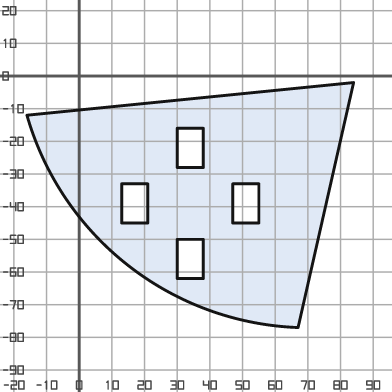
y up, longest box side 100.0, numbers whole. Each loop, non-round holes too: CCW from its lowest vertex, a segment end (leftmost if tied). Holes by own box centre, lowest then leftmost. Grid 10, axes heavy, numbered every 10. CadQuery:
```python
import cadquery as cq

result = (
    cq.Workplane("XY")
    .moveTo(67.0, -77.0)
    .lineTo(84.0, -2.0)
    .lineTo(-16.0, -12.0)
    .threePointArc((15.0, -58.0), (67.0, -77.0))
    .close()
    .moveTo(30.0, -62.0)
    .lineTo(38.0, -62.0)
    .lineTo(38.0, -50.0)
    .lineTo(30.0, -50.0)
    .close()
    .moveTo(13.0, -45.0)
    .lineTo(21.0, -45.0)
    .lineTo(21.0, -33.0)
    .lineTo(13.0, -33.0)
    .close()
    .moveTo(47.0, -45.0)
    .lineTo(55.0, -45.0)
    .lineTo(55.0, -33.0)
    .lineTo(47.0, -33.0)
    .close()
    .moveTo(30.0, -28.0)
    .lineTo(38.0, -28.0)
    .lineTo(38.0, -16.0)
    .lineTo(30.0, -16.0)
    .close()
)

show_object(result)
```